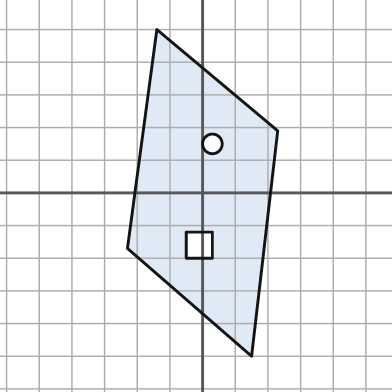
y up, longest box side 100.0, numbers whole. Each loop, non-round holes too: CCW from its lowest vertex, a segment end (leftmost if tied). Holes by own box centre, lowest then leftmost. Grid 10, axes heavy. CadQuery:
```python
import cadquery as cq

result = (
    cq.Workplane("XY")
    .moveTo(15.0, -50.0)
    .lineTo(23.0, 19.0)
    .lineTo(-14.0, 50.0)
    .lineTo(-23.0, -17.0)
    .close()
    .moveTo(-5.0, -20.0)
    .lineTo(3.0, -20.0)
    .lineTo(3.0, -12.0)
    .lineTo(-5.0, -12.0)
    .close()
    .moveTo(3.0, 15.0)
    .circle(3.0)
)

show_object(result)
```